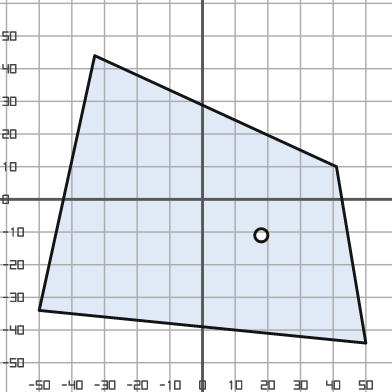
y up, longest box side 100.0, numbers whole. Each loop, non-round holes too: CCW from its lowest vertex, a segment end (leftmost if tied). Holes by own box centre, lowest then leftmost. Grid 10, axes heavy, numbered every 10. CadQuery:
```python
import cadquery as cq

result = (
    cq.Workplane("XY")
    .moveTo(50.0, -44.0)
    .lineTo(41.0, 10.0)
    .lineTo(-33.0, 44.0)
    .lineTo(-50.0, -34.0)
    .close()
    .moveTo(18.0, -11.0)
    .circle(2.0)
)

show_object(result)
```